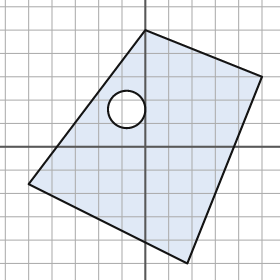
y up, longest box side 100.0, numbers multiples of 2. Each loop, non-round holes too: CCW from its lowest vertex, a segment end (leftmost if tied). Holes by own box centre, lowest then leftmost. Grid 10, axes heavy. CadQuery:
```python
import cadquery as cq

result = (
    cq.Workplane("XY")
    .moveTo(18.0, -50.0)
    .lineTo(50.0, 30.0)
    .lineTo(0.0, 50.0)
    .lineTo(-50.0, -16.0)
    .close()
    .moveTo(-8.0, 16.0)
    .circle(8.0)
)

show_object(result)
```